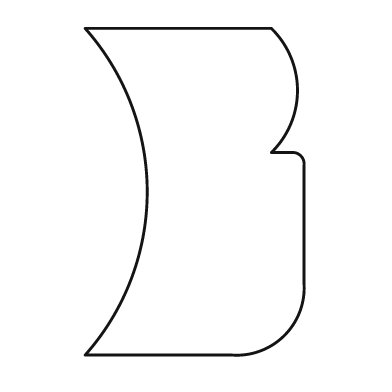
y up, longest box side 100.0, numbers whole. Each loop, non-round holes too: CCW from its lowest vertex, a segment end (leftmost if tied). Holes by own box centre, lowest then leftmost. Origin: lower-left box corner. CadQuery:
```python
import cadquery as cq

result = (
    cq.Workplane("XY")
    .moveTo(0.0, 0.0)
    .lineTo(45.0, 0.0)
    .threePointArc((61.0, 6.0), (67.0, 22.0))
    .lineTo(67.0, 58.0)
    .threePointArc((66.0, 61.0), (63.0, 62.0))
    .lineTo(57.0, 62.0)
    .threePointArc((65.0, 81.0), (57.0, 100.0))
    .lineTo(0.0, 100.0)
    .threePointArc((19.0, 50.0), (0.0, 0.0))
    .close()
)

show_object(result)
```